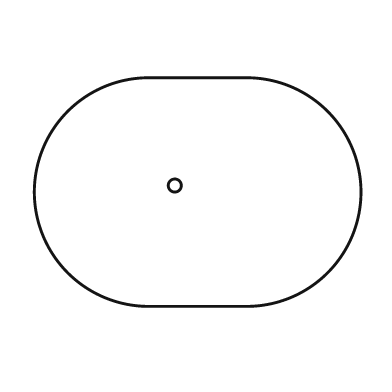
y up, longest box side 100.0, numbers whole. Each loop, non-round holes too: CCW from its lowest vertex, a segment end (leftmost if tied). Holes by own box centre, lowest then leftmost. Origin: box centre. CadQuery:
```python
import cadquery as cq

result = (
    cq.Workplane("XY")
    .moveTo(-15.0, -35.0)
    .lineTo(15.0, -35.0)
    .threePointArc((50.0, 0.0), (15.0, 35.0))
    .lineTo(-15.0, 35.0)
    .threePointArc((-50.0, 0.0), (-15.0, -35.0))
    .close()
    .moveTo(-7.0, 2.0)
    .circle(2.0)
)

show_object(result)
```